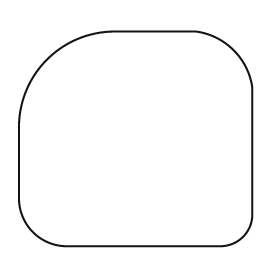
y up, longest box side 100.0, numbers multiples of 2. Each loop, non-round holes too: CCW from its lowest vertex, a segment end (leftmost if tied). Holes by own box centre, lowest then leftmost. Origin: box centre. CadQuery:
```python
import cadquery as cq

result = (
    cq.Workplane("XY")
    .moveTo(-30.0, -46.0)
    .lineTo(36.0, -46.0)
    .threePointArc((46.0, -42.0), (50.0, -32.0))
    .lineTo(50.0, 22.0)
    .threePointArc((42.0, 38.0), (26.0, 46.0))
    .lineTo(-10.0, 46.0)
    .threePointArc((-38.0, 34.0), (-50.0, 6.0))
    .lineTo(-50.0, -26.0)
    .threePointArc((-44.0, -40.0), (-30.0, -46.0))
    .close()
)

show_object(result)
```